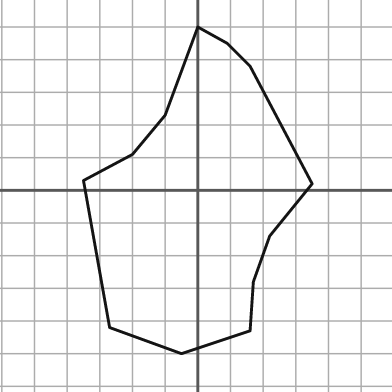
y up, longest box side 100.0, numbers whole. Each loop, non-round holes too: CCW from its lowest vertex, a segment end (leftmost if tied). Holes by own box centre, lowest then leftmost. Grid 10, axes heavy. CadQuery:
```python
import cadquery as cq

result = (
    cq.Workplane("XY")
    .moveTo(-5.0, -50.0)
    .lineTo(16.0, -43.0)
    .lineTo(17.0, -28.0)
    .lineTo(22.0, -14.0)
    .lineTo(35.0, 2.0)
    .lineTo(16.0, 38.0)
    .lineTo(9.0, 45.0)
    .lineTo(0.0, 50.0)
    .lineTo(-10.0, 23.0)
    .lineTo(-20.0, 11.0)
    .lineTo(-35.0, 3.0)
    .lineTo(-27.0, -42.0)
    .close()
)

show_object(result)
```